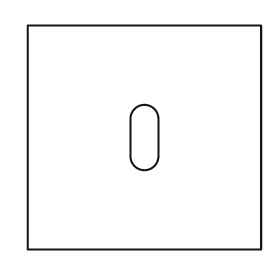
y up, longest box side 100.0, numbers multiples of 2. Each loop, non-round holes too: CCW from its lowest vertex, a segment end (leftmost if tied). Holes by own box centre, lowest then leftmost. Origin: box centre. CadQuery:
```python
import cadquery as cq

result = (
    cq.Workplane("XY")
    .moveTo(-50.0, -48.0)
    .lineTo(50.0, -48.0)
    .lineTo(50.0, 48.0)
    .lineTo(-50.0, 48.0)
    .close()
    .moveTo(-6.0, -8.0)
    .threePointArc((0.0, -14.0), (6.0, -8.0))
    .lineTo(6.0, 8.0)
    .threePointArc((0.0, 14.0), (-6.0, 8.0))
    .close()
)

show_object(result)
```